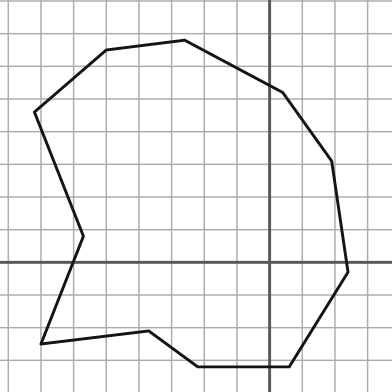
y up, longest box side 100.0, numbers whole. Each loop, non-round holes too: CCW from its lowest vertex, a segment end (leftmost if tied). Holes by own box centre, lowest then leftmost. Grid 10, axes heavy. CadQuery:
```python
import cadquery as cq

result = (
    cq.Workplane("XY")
    .moveTo(-22.0, -32.0)
    .lineTo(6.0, -32.0)
    .lineTo(24.0, -3.0)
    .lineTo(19.0, 31.0)
    .lineTo(4.0, 52.0)
    .lineTo(-26.0, 68.0)
    .lineTo(-50.0, 65.0)
    .lineTo(-72.0, 46.0)
    .lineTo(-57.0, 8.0)
    .lineTo(-70.0, -25.0)
    .lineTo(-37.0, -21.0)
    .close()
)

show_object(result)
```